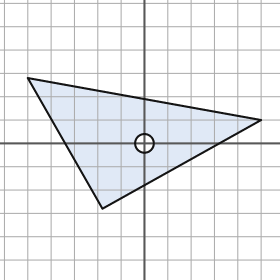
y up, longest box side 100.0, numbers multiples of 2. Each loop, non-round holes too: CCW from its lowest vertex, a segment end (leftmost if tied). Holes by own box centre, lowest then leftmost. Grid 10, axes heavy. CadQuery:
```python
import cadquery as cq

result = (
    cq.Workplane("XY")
    .moveTo(-18.0, -28.0)
    .lineTo(50.0, 10.0)
    .lineTo(-50.0, 28.0)
    .close()
    .moveTo(0.0, 0.0)
    .circle(4.0)
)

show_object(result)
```